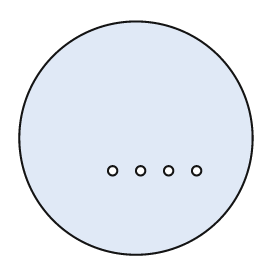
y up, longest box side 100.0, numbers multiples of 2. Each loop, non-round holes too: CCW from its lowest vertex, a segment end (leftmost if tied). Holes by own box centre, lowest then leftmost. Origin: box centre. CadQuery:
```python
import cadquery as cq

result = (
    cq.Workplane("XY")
    .moveTo(0.0, 0.0)
    .circle(50.0)
    .moveTo(-10.0, -14.0)
    .circle(2.0)
    .moveTo(2.0, -14.0)
    .circle(2.0)
    .moveTo(14.0, -14.0)
    .circle(2.0)
    .moveTo(26.0, -14.0)
    .circle(2.0)
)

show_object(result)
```